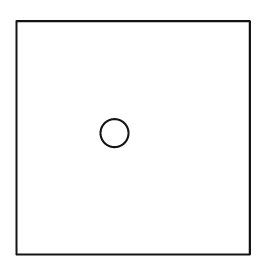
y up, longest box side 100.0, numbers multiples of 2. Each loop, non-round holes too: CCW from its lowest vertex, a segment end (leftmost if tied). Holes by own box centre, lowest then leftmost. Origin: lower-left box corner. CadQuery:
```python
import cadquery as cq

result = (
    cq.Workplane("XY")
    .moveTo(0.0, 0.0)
    .lineTo(100.0, 0.0)
    .lineTo(100.0, 100.0)
    .lineTo(0.0, 100.0)
    .close()
    .moveTo(42.0, 52.0)
    .circle(6.0)
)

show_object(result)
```